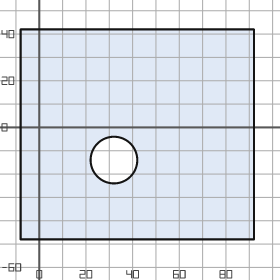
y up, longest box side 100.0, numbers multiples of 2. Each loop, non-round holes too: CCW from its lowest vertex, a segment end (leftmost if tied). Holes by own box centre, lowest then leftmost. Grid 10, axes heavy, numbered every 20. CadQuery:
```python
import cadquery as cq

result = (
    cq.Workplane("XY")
    .moveTo(-8.0, -48.0)
    .lineTo(92.0, -48.0)
    .lineTo(92.0, 42.0)
    .lineTo(-8.0, 42.0)
    .close()
    .moveTo(32.0, -14.0)
    .circle(10.0)
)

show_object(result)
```